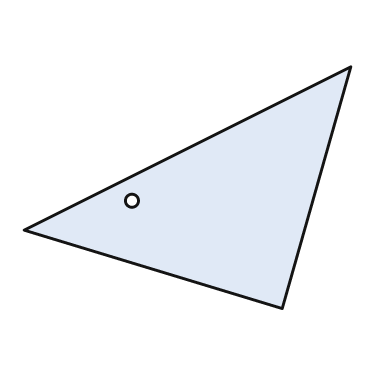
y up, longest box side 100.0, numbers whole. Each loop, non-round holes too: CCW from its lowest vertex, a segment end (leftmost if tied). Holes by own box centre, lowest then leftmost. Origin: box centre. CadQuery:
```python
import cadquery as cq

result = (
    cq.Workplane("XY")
    .moveTo(29.0, -37.0)
    .lineTo(50.0, 37.0)
    .lineTo(-50.0, -13.0)
    .close()
    .moveTo(-17.0, -4.0)
    .circle(2.0)
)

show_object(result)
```